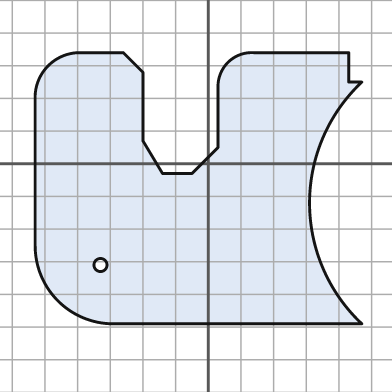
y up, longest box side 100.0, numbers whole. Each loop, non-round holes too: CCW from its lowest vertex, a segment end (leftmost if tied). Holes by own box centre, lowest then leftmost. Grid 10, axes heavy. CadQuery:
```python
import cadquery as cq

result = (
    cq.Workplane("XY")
    .moveTo(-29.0, -49.0)
    .lineTo(47.0, -49.0)
    .threePointArc((31.0, -12.0), (47.0, 25.0))
    .lineTo(43.0, 25.0)
    .lineTo(43.0, 34.0)
    .lineTo(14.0, 34.0)
    .threePointArc((6.0, 31.0), (3.0, 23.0))
    .lineTo(3.0, 5.0)
    .lineTo(-5.0, -3.0)
    .lineTo(-14.0, -3.0)
    .lineTo(-20.0, 7.0)
    .lineTo(-20.0, 28.0)
    .lineTo(-26.0, 34.0)
    .lineTo(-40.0, 34.0)
    .threePointArc((-49.0, 30.0), (-53.0, 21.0))
    .lineTo(-53.0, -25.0)
    .threePointArc((-46.0, -42.0), (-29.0, -49.0))
    .close()
    .moveTo(-33.0, -31.0)
    .circle(2.0)
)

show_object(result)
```